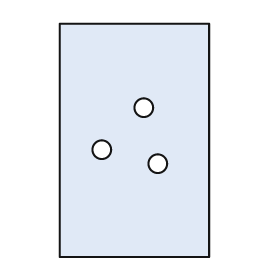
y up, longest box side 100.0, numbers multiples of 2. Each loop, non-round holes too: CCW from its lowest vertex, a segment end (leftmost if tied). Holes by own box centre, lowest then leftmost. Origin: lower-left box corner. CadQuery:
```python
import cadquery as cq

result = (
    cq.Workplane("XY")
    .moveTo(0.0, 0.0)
    .lineTo(64.0, 0.0)
    .lineTo(64.0, 100.0)
    .lineTo(0.0, 100.0)
    .close()
    .moveTo(42.0, 40.0)
    .circle(4.0)
    .moveTo(18.0, 46.0)
    .circle(4.0)
    .moveTo(36.0, 64.0)
    .circle(4.0)
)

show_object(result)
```